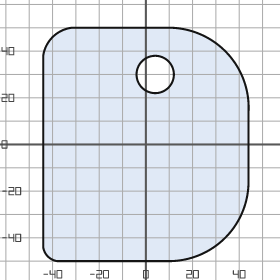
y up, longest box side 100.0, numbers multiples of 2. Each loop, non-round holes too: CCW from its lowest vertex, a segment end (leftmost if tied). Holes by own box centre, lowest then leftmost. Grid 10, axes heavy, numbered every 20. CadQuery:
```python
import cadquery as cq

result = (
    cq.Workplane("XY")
    .moveTo(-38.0, -50.0)
    .lineTo(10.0, -50.0)
    .threePointArc((34.0, -40.0), (44.0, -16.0))
    .lineTo(44.0, 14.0)
    .threePointArc((34.0, 40.0), (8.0, 50.0))
    .lineTo(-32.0, 50.0)
    .threePointArc((-40.0, 46.0), (-44.0, 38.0))
    .lineTo(-44.0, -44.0)
    .threePointArc((-42.0, -48.0), (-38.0, -50.0))
    .close()
    .moveTo(4.0, 30.0)
    .circle(8.0)
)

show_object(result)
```